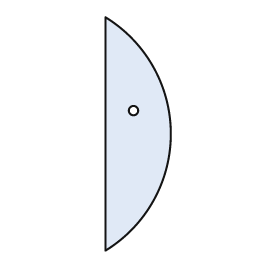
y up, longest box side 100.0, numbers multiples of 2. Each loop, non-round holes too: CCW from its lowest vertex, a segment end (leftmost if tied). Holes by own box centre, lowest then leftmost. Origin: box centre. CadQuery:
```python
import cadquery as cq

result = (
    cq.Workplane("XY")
    .moveTo(-14.0, -50.0)
    .threePointArc((14.0, 0.0), (-14.0, 50.0))
    .close()
    .moveTo(-2.0, 10.0)
    .circle(2.0)
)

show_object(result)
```